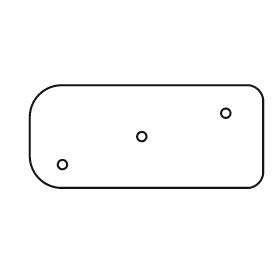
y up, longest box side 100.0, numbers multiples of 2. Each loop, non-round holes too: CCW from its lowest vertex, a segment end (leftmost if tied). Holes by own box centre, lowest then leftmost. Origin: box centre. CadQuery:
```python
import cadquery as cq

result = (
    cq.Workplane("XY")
    .moveTo(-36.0, -22.0)
    .lineTo(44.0, -22.0)
    .threePointArc((48.0, -20.0), (50.0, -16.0))
    .lineTo(50.0, 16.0)
    .threePointArc((48.0, 20.0), (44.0, 22.0))
    .lineTo(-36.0, 22.0)
    .threePointArc((-46.0, 18.0), (-50.0, 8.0))
    .lineTo(-50.0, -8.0)
    .threePointArc((-46.0, -18.0), (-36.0, -22.0))
    .close()
    .moveTo(-36.0, -12.0)
    .circle(2.0)
    .moveTo(-2.0, 0.0)
    .circle(2.0)
    .moveTo(34.0, 10.0)
    .circle(2.0)
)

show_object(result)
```